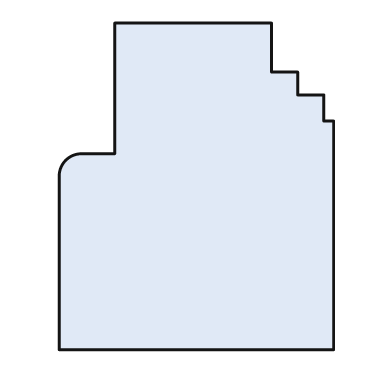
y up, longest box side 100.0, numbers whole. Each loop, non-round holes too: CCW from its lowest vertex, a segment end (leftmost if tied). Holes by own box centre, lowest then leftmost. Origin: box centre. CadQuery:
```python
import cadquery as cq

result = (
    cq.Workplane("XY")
    .moveTo(-42.0, -50.0)
    .lineTo(42.0, -50.0)
    .lineTo(42.0, 20.0)
    .lineTo(39.0, 20.0)
    .lineTo(39.0, 28.0)
    .lineTo(31.0, 28.0)
    .lineTo(31.0, 35.0)
    .lineTo(23.0, 35.0)
    .lineTo(23.0, 50.0)
    .lineTo(-25.0, 50.0)
    .lineTo(-25.0, 10.0)
    .lineTo(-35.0, 10.0)
    .threePointArc((-40.0, 8.0), (-42.0, 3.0))
    .close()
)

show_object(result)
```